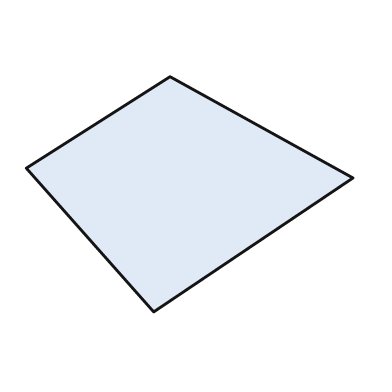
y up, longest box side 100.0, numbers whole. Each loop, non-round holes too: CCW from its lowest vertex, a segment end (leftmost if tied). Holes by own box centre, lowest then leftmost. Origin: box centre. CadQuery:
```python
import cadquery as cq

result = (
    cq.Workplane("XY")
    .moveTo(-11.0, -36.0)
    .lineTo(50.0, 5.0)
    .lineTo(-6.0, 36.0)
    .lineTo(-50.0, 8.0)
    .close()
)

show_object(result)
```